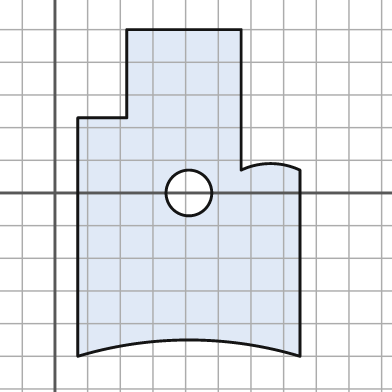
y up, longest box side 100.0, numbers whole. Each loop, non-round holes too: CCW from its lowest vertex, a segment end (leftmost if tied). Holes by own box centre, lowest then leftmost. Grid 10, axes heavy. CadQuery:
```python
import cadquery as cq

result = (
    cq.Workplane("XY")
    .moveTo(7.0, -50.0)
    .threePointArc((41.0, -45.0), (75.0, -50.0))
    .lineTo(75.0, 7.0)
    .threePointArc((66.0, 9.0), (57.0, 7.0))
    .lineTo(57.0, 50.0)
    .lineTo(22.0, 50.0)
    .lineTo(22.0, 23.0)
    .lineTo(7.0, 23.0)
    .close()
    .moveTo(41.0, 0.0)
    .circle(7.0)
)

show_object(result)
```